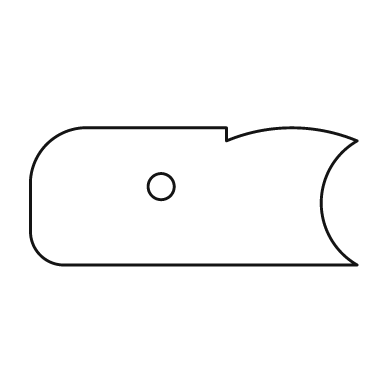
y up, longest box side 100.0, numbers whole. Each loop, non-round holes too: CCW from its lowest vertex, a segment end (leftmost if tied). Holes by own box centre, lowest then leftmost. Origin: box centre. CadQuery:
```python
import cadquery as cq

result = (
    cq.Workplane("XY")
    .moveTo(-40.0, -21.0)
    .lineTo(50.0, -21.0)
    .threePointArc((39.0, -2.0), (50.0, 17.0))
    .threePointArc((30.0, 21.0), (10.0, 17.0))
    .lineTo(10.0, 21.0)
    .lineTo(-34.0, 21.0)
    .threePointArc((-45.0, 16.0), (-50.0, 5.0))
    .lineTo(-50.0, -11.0)
    .threePointArc((-47.0, -18.0), (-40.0, -21.0))
    .close()
    .moveTo(-10.0, 3.0)
    .circle(4.0)
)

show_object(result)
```